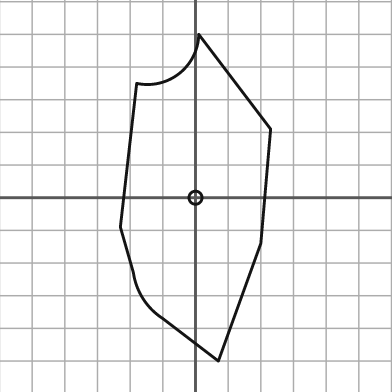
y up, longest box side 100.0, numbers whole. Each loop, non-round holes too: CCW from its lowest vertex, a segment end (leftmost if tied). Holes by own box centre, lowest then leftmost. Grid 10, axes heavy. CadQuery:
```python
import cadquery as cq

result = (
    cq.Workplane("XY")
    .moveTo(7.0, -50.0)
    .lineTo(20.0, -14.0)
    .lineTo(23.0, 21.0)
    .lineTo(1.0, 50.0)
    .threePointArc((-5.0, 38.0), (-18.0, 35.0))
    .lineTo(-23.0, -9.0)
    .lineTo(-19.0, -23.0)
    .threePointArc((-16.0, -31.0), (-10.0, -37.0))
    .close()
    .moveTo(0.0, 0.0)
    .circle(2.0)
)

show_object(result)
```